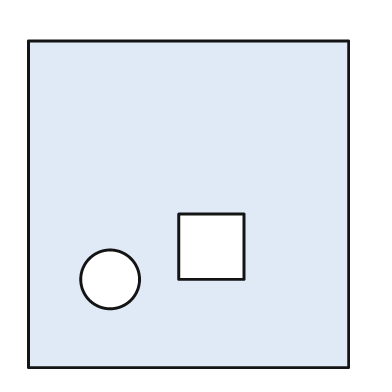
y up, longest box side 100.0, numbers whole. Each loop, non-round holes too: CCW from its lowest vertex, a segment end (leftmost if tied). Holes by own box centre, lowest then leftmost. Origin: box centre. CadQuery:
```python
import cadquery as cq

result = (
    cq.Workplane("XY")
    .moveTo(-49.0, -50.0)
    .lineTo(49.0, -50.0)
    .lineTo(49.0, 50.0)
    .lineTo(-49.0, 50.0)
    .close()
    .moveTo(-24.0, -23.0)
    .circle(9.0)
    .moveTo(-3.0, -23.0)
    .lineTo(17.0, -23.0)
    .lineTo(17.0, -3.0)
    .lineTo(-3.0, -3.0)
    .close()
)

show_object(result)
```